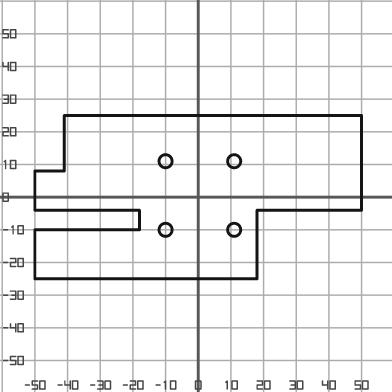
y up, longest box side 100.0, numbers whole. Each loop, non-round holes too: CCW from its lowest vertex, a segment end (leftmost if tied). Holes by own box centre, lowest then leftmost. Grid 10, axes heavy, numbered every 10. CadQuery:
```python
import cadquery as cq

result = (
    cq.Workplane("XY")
    .moveTo(-50.0, -25.0)
    .lineTo(18.0, -25.0)
    .lineTo(18.0, -4.0)
    .lineTo(50.0, -4.0)
    .lineTo(50.0, 25.0)
    .lineTo(-41.0, 25.0)
    .lineTo(-41.0, 8.0)
    .lineTo(-50.0, 8.0)
    .lineTo(-50.0, -4.0)
    .lineTo(-18.0, -4.0)
    .lineTo(-18.0, -10.0)
    .lineTo(-50.0, -10.0)
    .close()
    .moveTo(-10.0, -10.0)
    .circle(2.0)
    .moveTo(11.0, -10.0)
    .circle(2.0)
    .moveTo(-10.0, 11.0)
    .circle(2.0)
    .moveTo(11.0, 11.0)
    .circle(2.0)
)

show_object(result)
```